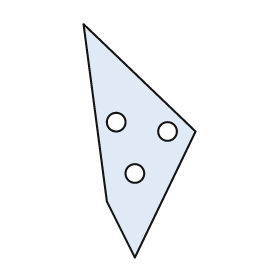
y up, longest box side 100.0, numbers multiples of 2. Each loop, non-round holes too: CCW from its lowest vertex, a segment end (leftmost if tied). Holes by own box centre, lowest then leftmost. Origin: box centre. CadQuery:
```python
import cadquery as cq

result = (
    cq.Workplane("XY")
    .moveTo(-2.0, -50.0)
    .lineTo(24.0, 4.0)
    .lineTo(-24.0, 50.0)
    .lineTo(-14.0, -26.0)
    .close()
    .moveTo(-2.0, -14.0)
    .circle(4.0)
    .moveTo(12.0, 4.0)
    .circle(4.0)
    .moveTo(-10.0, 8.0)
    .circle(4.0)
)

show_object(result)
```